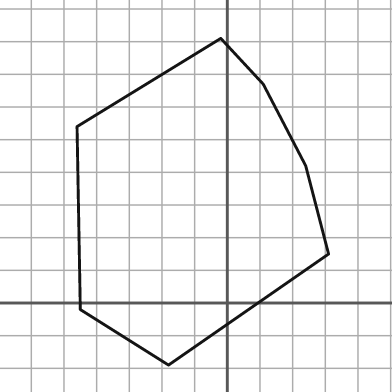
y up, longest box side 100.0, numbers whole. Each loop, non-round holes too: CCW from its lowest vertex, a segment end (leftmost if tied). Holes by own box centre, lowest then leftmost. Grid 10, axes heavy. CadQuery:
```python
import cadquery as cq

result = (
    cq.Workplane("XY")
    .moveTo(-18.0, -19.0)
    .lineTo(31.0, 15.0)
    .lineTo(24.0, 42.0)
    .lineTo(11.0, 67.0)
    .lineTo(-2.0, 81.0)
    .lineTo(-46.0, 54.0)
    .lineTo(-45.0, -2.0)
    .close()
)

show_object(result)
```